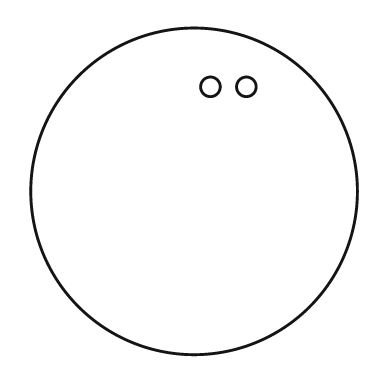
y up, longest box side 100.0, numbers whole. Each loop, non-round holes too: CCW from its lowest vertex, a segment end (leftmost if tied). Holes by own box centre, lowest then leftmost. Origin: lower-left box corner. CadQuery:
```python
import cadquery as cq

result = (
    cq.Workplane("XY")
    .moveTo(50.0, 50.0)
    .circle(50.0)
    .moveTo(55.0, 82.0)
    .circle(3.0)
    .moveTo(66.0, 82.0)
    .circle(3.0)
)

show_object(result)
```